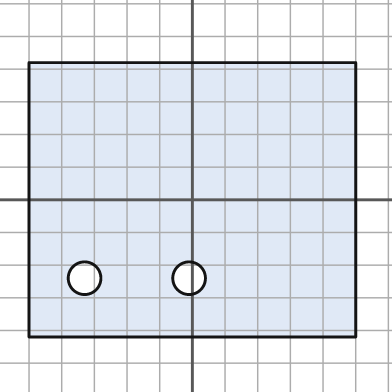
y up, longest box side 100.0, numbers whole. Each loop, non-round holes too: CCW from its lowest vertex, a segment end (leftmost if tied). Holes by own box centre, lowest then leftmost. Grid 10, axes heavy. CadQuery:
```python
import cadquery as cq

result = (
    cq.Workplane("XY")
    .moveTo(-50.0, -42.0)
    .lineTo(50.0, -42.0)
    .lineTo(50.0, 42.0)
    .lineTo(-50.0, 42.0)
    .close()
    .moveTo(-33.0, -24.0)
    .circle(5.0)
    .moveTo(-1.0, -24.0)
    .circle(5.0)
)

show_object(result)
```